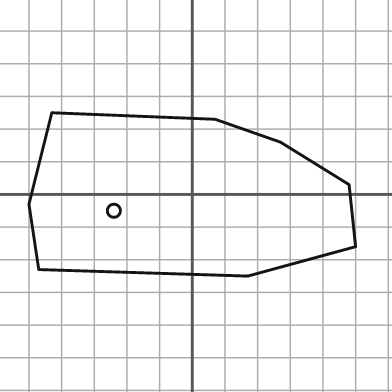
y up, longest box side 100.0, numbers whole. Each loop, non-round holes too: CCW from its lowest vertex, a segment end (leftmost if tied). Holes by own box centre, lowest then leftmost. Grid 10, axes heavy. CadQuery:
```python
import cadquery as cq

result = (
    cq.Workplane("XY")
    .moveTo(17.0, -25.0)
    .lineTo(50.0, -16.0)
    .lineTo(48.0, 3.0)
    .lineTo(27.0, 16.0)
    .lineTo(7.0, 23.0)
    .lineTo(-43.0, 25.0)
    .lineTo(-50.0, -3.0)
    .lineTo(-47.0, -23.0)
    .close()
    .moveTo(-24.0, -5.0)
    .circle(2.0)
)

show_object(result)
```